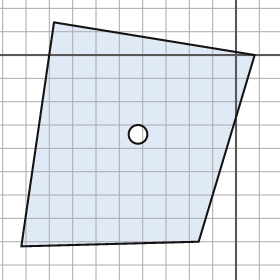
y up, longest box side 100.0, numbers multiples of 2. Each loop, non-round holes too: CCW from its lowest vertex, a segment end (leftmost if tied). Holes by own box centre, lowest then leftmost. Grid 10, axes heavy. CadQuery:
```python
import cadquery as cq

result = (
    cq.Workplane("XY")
    .moveTo(-92.0, -82.0)
    .lineTo(-16.0, -80.0)
    .lineTo(8.0, 0.0)
    .lineTo(-78.0, 14.0)
    .close()
    .moveTo(-42.0, -34.0)
    .circle(4.0)
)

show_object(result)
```